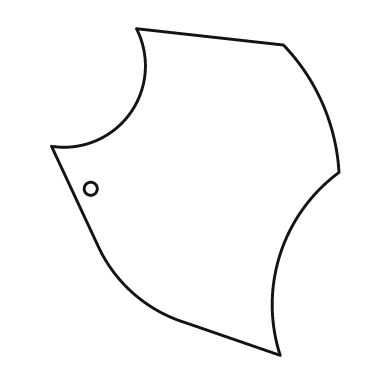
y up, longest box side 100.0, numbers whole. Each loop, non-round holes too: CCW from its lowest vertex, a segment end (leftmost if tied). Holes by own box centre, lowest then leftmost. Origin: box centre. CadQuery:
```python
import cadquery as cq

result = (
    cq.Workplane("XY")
    .moveTo(26.0, -50.0)
    .threePointArc((26.0, -19.0), (44.0, 6.0))
    .threePointArc((39.0, 27.0), (27.0, 45.0))
    .lineTo(-18.0, 50.0)
    .threePointArc((-20.0, 24.0), (-44.0, 14.0))
    .lineTo(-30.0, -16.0)
    .threePointArc((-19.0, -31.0), (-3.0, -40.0))
    .close()
    .moveTo(-32.0, 1.0)
    .circle(2.0)
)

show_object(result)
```